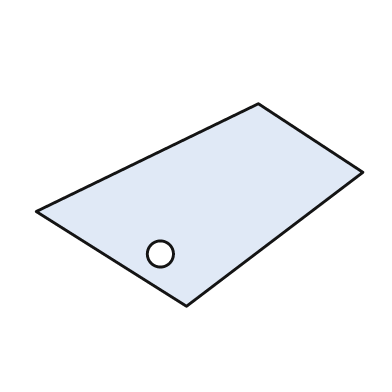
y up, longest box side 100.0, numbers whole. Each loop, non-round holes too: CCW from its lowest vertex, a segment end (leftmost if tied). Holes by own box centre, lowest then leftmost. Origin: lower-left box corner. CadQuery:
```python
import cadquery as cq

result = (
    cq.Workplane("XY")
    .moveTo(46.0, 0.0)
    .lineTo(100.0, 41.0)
    .lineTo(68.0, 62.0)
    .lineTo(0.0, 29.0)
    .close()
    .moveTo(38.0, 16.0)
    .circle(4.0)
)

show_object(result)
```